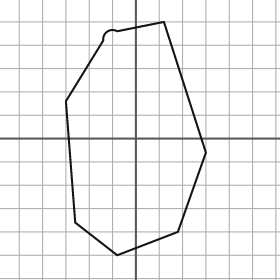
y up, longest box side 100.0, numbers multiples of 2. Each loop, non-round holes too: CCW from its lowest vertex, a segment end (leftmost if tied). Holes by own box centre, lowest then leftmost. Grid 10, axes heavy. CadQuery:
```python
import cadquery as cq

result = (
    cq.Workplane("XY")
    .moveTo(-8.0, -50.0)
    .lineTo(18.0, -40.0)
    .lineTo(30.0, -6.0)
    .lineTo(12.0, 50.0)
    .lineTo(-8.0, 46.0)
    .threePointArc((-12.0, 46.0), (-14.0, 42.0))
    .lineTo(-30.0, 16.0)
    .lineTo(-26.0, -36.0)
    .close()
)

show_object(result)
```